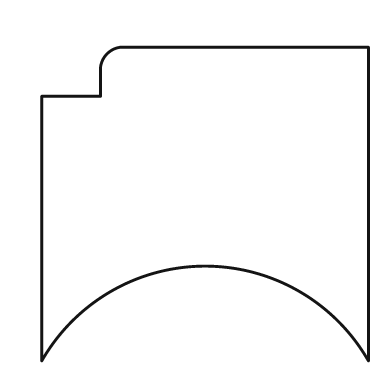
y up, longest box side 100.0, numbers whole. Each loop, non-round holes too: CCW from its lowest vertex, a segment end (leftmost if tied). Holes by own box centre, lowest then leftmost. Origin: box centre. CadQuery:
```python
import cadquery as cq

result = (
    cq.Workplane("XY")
    .moveTo(-50.0, -48.0)
    .threePointArc((0.0, -19.0), (50.0, -48.0))
    .lineTo(50.0, 48.0)
    .lineTo(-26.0, 48.0)
    .threePointArc((-30.0, 46.0), (-32.0, 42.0))
    .lineTo(-32.0, 33.0)
    .lineTo(-50.0, 33.0)
    .close()
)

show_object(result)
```